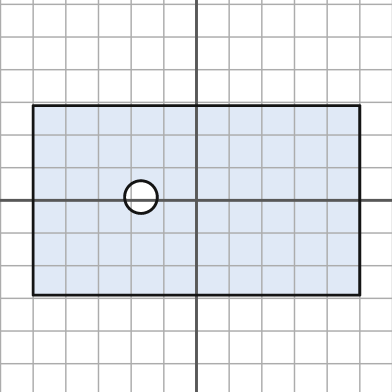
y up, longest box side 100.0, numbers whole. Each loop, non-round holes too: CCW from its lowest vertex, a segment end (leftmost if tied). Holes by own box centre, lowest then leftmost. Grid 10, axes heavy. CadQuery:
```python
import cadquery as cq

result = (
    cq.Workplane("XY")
    .moveTo(-50.0, -29.0)
    .lineTo(50.0, -29.0)
    .lineTo(50.0, 29.0)
    .lineTo(-50.0, 29.0)
    .close()
    .moveTo(-17.0, 1.0)
    .circle(5.0)
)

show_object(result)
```